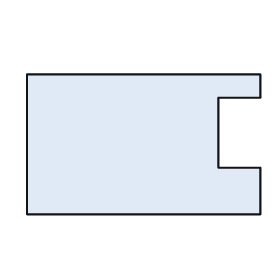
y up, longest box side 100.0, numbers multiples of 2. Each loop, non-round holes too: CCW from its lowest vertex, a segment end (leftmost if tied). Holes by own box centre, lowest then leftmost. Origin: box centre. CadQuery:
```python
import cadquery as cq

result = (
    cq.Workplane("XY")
    .moveTo(-50.0, -30.0)
    .lineTo(50.0, -30.0)
    .lineTo(50.0, -10.0)
    .lineTo(32.0, -10.0)
    .lineTo(32.0, 20.0)
    .lineTo(50.0, 20.0)
    .lineTo(50.0, 30.0)
    .lineTo(-50.0, 30.0)
    .close()
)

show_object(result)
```